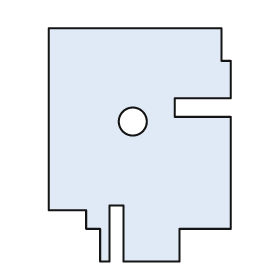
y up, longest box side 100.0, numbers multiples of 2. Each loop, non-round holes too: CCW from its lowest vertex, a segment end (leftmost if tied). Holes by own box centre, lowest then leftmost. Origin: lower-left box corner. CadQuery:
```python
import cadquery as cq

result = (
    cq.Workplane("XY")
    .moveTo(22.0, 0.0)
    .lineTo(26.0, 0.0)
    .lineTo(26.0, 24.0)
    .lineTo(32.0, 24.0)
    .lineTo(32.0, 0.0)
    .lineTo(56.0, 0.0)
    .lineTo(56.0, 14.0)
    .lineTo(78.0, 14.0)
    .lineTo(78.0, 62.0)
    .lineTo(54.0, 62.0)
    .lineTo(54.0, 70.0)
    .lineTo(78.0, 70.0)
    .lineTo(78.0, 86.0)
    .lineTo(74.0, 86.0)
    .lineTo(74.0, 100.0)
    .lineTo(0.0, 100.0)
    .lineTo(0.0, 22.0)
    .lineTo(16.0, 22.0)
    .lineTo(16.0, 14.0)
    .lineTo(22.0, 14.0)
    .close()
    .moveTo(36.0, 60.0)
    .circle(6.0)
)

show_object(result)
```